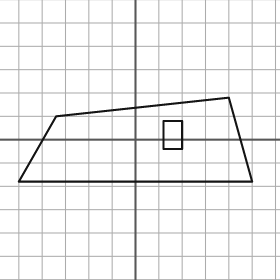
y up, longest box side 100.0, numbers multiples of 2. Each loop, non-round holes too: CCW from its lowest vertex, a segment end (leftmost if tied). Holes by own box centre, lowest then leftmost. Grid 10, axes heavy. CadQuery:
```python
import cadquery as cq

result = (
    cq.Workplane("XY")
    .moveTo(-50.0, -18.0)
    .lineTo(50.0, -18.0)
    .lineTo(40.0, 18.0)
    .lineTo(-34.0, 10.0)
    .close()
    .moveTo(12.0, -4.0)
    .lineTo(20.0, -4.0)
    .lineTo(20.0, 8.0)
    .lineTo(12.0, 8.0)
    .close()
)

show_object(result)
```